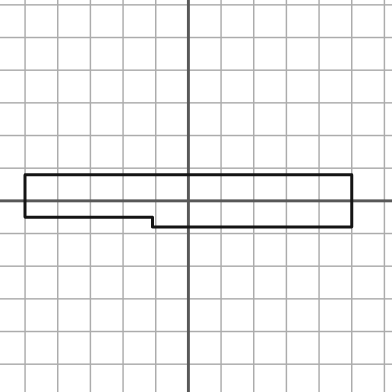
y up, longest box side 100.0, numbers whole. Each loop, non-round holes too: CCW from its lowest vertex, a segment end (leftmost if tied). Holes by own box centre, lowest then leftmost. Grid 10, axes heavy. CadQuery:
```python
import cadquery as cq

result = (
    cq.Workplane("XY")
    .moveTo(-11.0, -8.0)
    .lineTo(50.0, -8.0)
    .lineTo(50.0, 8.0)
    .lineTo(-50.0, 8.0)
    .lineTo(-50.0, -5.0)
    .lineTo(-11.0, -5.0)
    .close()
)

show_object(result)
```